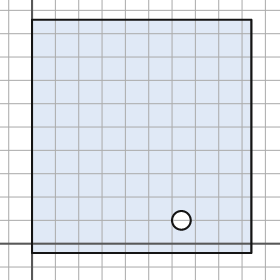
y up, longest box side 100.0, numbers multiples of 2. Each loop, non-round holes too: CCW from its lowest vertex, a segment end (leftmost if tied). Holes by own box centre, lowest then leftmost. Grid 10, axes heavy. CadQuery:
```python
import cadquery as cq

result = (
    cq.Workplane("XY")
    .moveTo(0.0, -4.0)
    .lineTo(94.0, -4.0)
    .lineTo(94.0, 96.0)
    .lineTo(0.0, 96.0)
    .close()
    .moveTo(64.0, 10.0)
    .circle(4.0)
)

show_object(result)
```